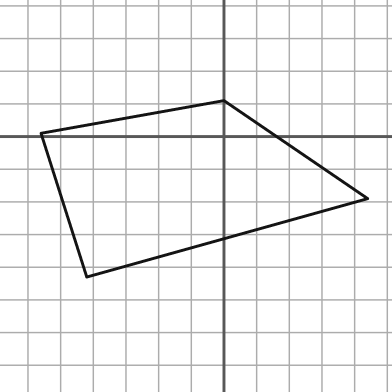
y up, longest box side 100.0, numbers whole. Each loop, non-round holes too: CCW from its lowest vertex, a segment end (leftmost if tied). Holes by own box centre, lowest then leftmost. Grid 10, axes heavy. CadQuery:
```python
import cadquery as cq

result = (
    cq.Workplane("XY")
    .moveTo(-42.0, -43.0)
    .lineTo(44.0, -19.0)
    .lineTo(0.0, 11.0)
    .lineTo(-56.0, 1.0)
    .close()
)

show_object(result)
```